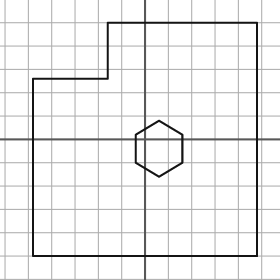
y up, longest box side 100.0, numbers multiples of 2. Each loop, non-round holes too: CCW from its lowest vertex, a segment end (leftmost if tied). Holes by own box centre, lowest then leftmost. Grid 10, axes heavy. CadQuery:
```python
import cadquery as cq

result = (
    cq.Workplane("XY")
    .moveTo(-48.0, -50.0)
    .lineTo(48.0, -50.0)
    .lineTo(48.0, 50.0)
    .lineTo(-16.0, 50.0)
    .lineTo(-16.0, 26.0)
    .lineTo(-48.0, 26.0)
    .close()
    .moveTo(6.0, -16.0)
    .lineTo(16.0, -10.0)
    .lineTo(16.0, 2.0)
    .lineTo(6.0, 8.0)
    .lineTo(-4.0, 2.0)
    .lineTo(-4.0, -10.0)
    .close()
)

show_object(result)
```